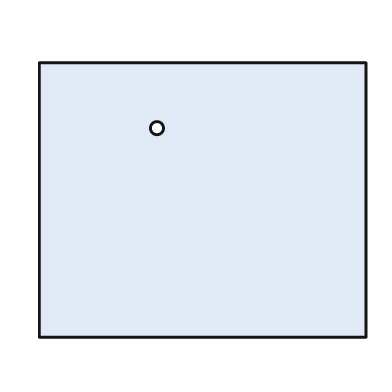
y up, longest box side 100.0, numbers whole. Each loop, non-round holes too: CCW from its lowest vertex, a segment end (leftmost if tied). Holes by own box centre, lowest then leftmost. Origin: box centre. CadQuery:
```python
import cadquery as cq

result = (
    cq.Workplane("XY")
    .moveTo(-50.0, -42.0)
    .lineTo(50.0, -42.0)
    .lineTo(50.0, 42.0)
    .lineTo(-50.0, 42.0)
    .close()
    .moveTo(-14.0, 22.0)
    .circle(2.0)
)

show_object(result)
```